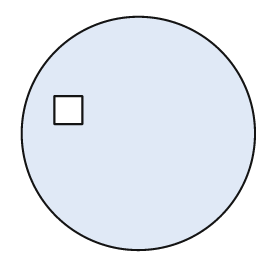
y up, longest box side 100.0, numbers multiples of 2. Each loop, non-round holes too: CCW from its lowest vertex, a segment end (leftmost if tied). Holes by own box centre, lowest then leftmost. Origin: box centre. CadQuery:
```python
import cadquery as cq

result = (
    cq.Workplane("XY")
    .moveTo(0.0, 0.0)
    .circle(50.0)
    .moveTo(-36.0, 4.0)
    .lineTo(-24.0, 4.0)
    .lineTo(-24.0, 16.0)
    .lineTo(-36.0, 16.0)
    .close()
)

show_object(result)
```